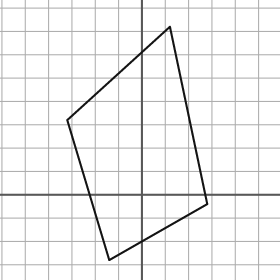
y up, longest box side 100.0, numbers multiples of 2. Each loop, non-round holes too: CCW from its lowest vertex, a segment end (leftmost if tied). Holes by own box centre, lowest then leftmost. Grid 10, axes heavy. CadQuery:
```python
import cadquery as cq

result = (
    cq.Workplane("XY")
    .moveTo(-14.0, -28.0)
    .lineTo(28.0, -4.0)
    .lineTo(12.0, 72.0)
    .lineTo(-32.0, 32.0)
    .close()
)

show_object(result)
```